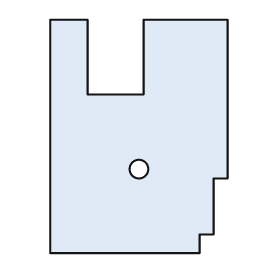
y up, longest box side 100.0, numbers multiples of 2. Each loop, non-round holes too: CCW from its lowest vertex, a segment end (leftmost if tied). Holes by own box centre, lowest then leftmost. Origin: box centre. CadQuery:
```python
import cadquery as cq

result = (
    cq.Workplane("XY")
    .moveTo(-38.0, -50.0)
    .lineTo(26.0, -50.0)
    .lineTo(26.0, -42.0)
    .lineTo(32.0, -42.0)
    .lineTo(32.0, -18.0)
    .lineTo(38.0, -18.0)
    .lineTo(38.0, 50.0)
    .lineTo(2.0, 50.0)
    .lineTo(2.0, 18.0)
    .lineTo(-22.0, 18.0)
    .lineTo(-22.0, 50.0)
    .lineTo(-38.0, 50.0)
    .close()
    .moveTo(0.0, -14.0)
    .circle(4.0)
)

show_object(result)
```